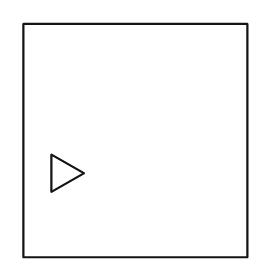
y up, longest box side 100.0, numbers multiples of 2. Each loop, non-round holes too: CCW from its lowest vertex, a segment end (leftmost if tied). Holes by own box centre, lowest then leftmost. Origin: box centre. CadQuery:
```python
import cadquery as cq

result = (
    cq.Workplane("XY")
    .moveTo(-48.0, -50.0)
    .lineTo(48.0, -50.0)
    .lineTo(48.0, 50.0)
    .lineTo(-48.0, 50.0)
    .close()
    .moveTo(-36.0, -22.0)
    .lineTo(-22.0, -14.0)
    .lineTo(-36.0, -6.0)
    .close()
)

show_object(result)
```